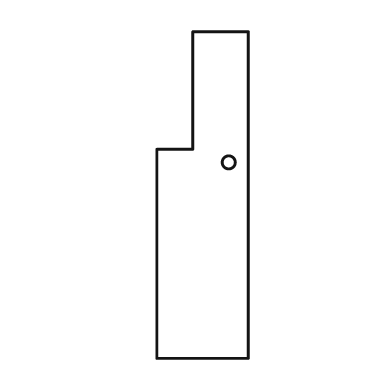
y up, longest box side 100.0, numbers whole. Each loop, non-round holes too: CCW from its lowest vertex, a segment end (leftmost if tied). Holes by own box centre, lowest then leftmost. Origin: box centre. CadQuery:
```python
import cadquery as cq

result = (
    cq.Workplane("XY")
    .moveTo(-14.0, -50.0)
    .lineTo(14.0, -50.0)
    .lineTo(14.0, 50.0)
    .lineTo(-3.0, 50.0)
    .lineTo(-3.0, 14.0)
    .lineTo(-14.0, 14.0)
    .close()
    .moveTo(8.0, 10.0)
    .circle(2.0)
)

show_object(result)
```